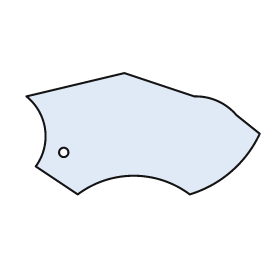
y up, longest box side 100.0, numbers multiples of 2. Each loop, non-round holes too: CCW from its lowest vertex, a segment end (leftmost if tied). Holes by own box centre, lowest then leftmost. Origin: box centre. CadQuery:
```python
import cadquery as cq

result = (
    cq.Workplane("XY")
    .moveTo(-28.0, -26.0)
    .threePointArc((-4.0, -18.0), (20.0, -26.0))
    .threePointArc((38.0, -16.0), (50.0, 0.0))
    .lineTo(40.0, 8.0)
    .threePointArc((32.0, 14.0), (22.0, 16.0))
    .lineTo(-8.0, 26.0)
    .lineTo(-50.0, 16.0)
    .threePointArc((-42.0, 2.0), (-46.0, -14.0))
    .close()
    .moveTo(-34.0, -8.0)
    .circle(2.0)
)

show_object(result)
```